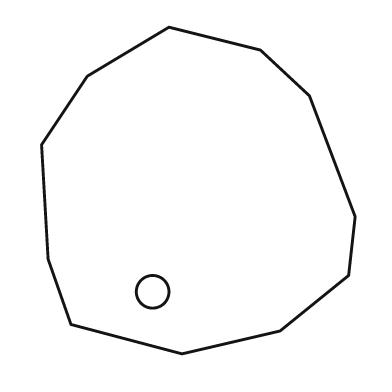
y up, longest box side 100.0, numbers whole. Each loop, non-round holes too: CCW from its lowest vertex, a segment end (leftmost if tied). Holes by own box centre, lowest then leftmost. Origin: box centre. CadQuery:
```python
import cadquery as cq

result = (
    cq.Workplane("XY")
    .moveTo(-5.0, -50.0)
    .lineTo(25.0, -43.0)
    .lineTo(46.0, -26.0)
    .lineTo(48.0, -8.0)
    .lineTo(34.0, 29.0)
    .lineTo(19.0, 43.0)
    .lineTo(-9.0, 50.0)
    .lineTo(-34.0, 35.0)
    .lineTo(-48.0, 14.0)
    .lineTo(-46.0, -21.0)
    .lineTo(-39.0, -41.0)
    .close()
    .moveTo(-14.0, -31.0)
    .circle(5.0)
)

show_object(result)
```